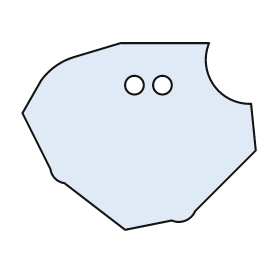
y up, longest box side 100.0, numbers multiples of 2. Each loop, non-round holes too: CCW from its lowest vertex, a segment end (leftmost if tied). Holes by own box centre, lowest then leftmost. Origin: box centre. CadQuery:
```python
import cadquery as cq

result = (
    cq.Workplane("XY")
    .moveTo(-6.0, -40.0)
    .lineTo(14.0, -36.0)
    .threePointArc((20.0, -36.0), (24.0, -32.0))
    .lineTo(50.0, -6.0)
    .lineTo(48.0, 14.0)
    .threePointArc((32.0, 22.0), (30.0, 40.0))
    .lineTo(-8.0, 40.0)
    .lineTo(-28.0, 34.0)
    .threePointArc((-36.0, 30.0), (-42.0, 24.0))
    .lineTo(-50.0, 10.0)
    .lineTo(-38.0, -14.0)
    .threePointArc((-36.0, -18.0), (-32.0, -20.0))
    .close()
    .moveTo(-2.0, 22.0)
    .circle(4.0)
    .moveTo(10.0, 22.0)
    .circle(4.0)
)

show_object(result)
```